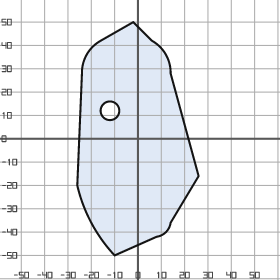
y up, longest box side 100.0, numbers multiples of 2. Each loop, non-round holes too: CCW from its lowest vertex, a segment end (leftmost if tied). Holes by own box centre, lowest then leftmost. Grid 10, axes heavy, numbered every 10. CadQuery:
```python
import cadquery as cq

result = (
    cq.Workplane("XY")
    .moveTo(-10.0, -50.0)
    .lineTo(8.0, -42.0)
    .threePointArc((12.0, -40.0), (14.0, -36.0))
    .lineTo(26.0, -16.0)
    .lineTo(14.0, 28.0)
    .threePointArc((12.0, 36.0), (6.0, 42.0))
    .lineTo(-2.0, 50.0)
    .lineTo(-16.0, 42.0)
    .threePointArc((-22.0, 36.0), (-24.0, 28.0))
    .lineTo(-26.0, -20.0)
    .threePointArc((-20.0, -36.0), (-10.0, -50.0))
    .close()
    .moveTo(-12.0, 12.0)
    .circle(4.0)
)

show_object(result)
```